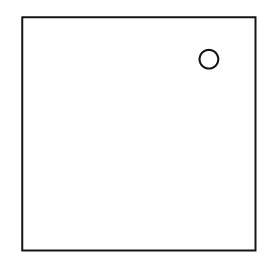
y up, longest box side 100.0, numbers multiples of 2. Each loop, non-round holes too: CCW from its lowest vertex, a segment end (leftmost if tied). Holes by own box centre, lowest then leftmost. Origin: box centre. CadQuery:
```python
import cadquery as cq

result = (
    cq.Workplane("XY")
    .moveTo(-50.0, -50.0)
    .lineTo(50.0, -50.0)
    .lineTo(50.0, 50.0)
    .lineTo(-50.0, 50.0)
    .close()
    .moveTo(30.0, 32.0)
    .circle(4.0)
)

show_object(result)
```